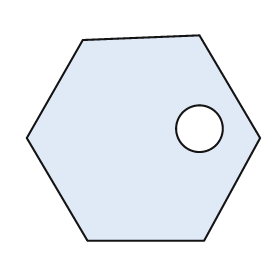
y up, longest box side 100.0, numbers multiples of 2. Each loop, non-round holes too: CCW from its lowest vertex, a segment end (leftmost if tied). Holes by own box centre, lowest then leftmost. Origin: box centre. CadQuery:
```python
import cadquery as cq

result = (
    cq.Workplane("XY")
    .moveTo(-24.0, -44.0)
    .lineTo(26.0, -44.0)
    .lineTo(50.0, 0.0)
    .lineTo(24.0, 44.0)
    .lineTo(-26.0, 42.0)
    .lineTo(-50.0, 0.0)
    .close()
    .moveTo(24.0, 4.0)
    .circle(10.0)
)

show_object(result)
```